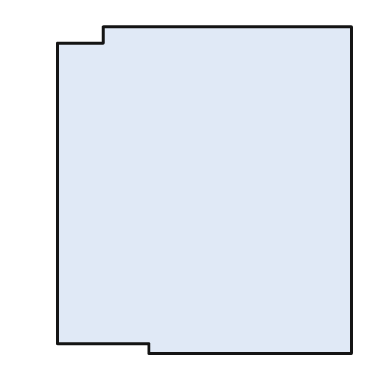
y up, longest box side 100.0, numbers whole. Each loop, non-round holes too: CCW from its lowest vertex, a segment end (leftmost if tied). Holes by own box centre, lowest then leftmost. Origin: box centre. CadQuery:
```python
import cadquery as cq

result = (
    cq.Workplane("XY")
    .moveTo(-17.0, -50.0)
    .lineTo(45.0, -50.0)
    .lineTo(45.0, 50.0)
    .lineTo(-31.0, 50.0)
    .lineTo(-31.0, 45.0)
    .lineTo(-45.0, 45.0)
    .lineTo(-45.0, -47.0)
    .lineTo(-17.0, -47.0)
    .close()
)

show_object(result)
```